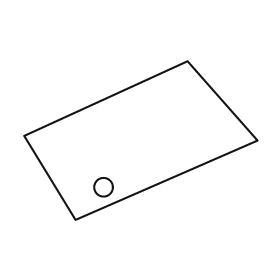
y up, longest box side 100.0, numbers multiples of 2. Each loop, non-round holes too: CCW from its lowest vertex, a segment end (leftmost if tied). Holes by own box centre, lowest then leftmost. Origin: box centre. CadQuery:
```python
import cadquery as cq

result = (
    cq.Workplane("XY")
    .moveTo(-28.0, -34.0)
    .lineTo(50.0, 0.0)
    .lineTo(20.0, 34.0)
    .lineTo(-50.0, 2.0)
    .close()
    .moveTo(-16.0, -20.0)
    .circle(4.0)
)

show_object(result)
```